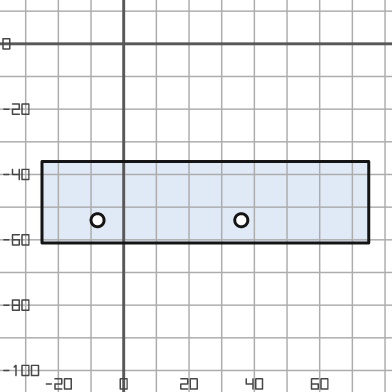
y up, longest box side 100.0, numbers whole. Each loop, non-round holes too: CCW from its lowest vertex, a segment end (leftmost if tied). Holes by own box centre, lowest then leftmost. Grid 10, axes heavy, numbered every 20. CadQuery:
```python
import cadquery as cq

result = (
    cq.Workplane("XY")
    .moveTo(-25.0, -61.0)
    .lineTo(75.0, -61.0)
    .lineTo(75.0, -36.0)
    .lineTo(-25.0, -36.0)
    .close()
    .moveTo(-8.0, -54.0)
    .circle(2.0)
    .moveTo(36.0, -54.0)
    .circle(2.0)
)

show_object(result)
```